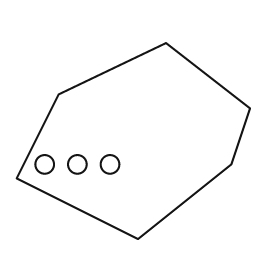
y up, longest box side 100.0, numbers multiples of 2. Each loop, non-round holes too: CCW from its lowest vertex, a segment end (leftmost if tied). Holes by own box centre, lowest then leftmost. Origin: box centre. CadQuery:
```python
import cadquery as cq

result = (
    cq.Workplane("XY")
    .moveTo(2.0, -42.0)
    .lineTo(42.0, -10.0)
    .lineTo(50.0, 14.0)
    .lineTo(14.0, 42.0)
    .lineTo(-32.0, 20.0)
    .lineTo(-50.0, -16.0)
    .close()
    .moveTo(-38.0, -10.0)
    .circle(4.0)
    .moveTo(-24.0, -10.0)
    .circle(4.0)
    .moveTo(-10.0, -10.0)
    .circle(4.0)
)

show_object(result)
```